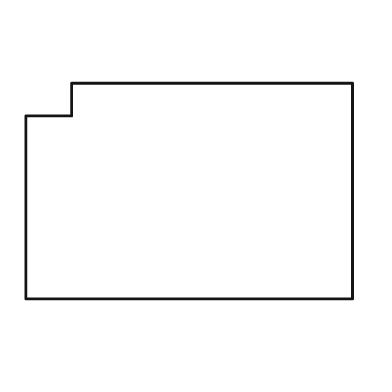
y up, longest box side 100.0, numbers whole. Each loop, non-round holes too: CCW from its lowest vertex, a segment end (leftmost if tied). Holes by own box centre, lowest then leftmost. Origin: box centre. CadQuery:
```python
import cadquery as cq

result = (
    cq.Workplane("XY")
    .moveTo(-50.0, -33.0)
    .lineTo(50.0, -33.0)
    .lineTo(50.0, 33.0)
    .lineTo(-36.0, 33.0)
    .lineTo(-36.0, 23.0)
    .lineTo(-50.0, 23.0)
    .close()
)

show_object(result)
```